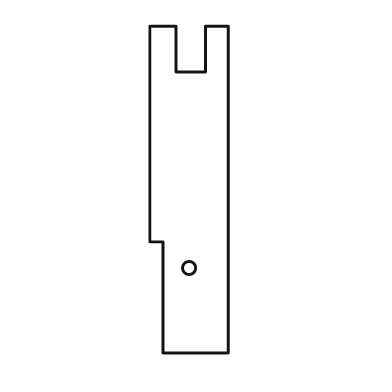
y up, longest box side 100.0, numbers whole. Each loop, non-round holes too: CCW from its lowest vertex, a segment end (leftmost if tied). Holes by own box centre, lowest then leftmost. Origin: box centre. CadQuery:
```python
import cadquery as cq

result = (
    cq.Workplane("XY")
    .moveTo(-8.0, -50.0)
    .lineTo(12.0, -50.0)
    .lineTo(12.0, 50.0)
    .lineTo(5.0, 50.0)
    .lineTo(5.0, 36.0)
    .lineTo(-4.0, 36.0)
    .lineTo(-4.0, 50.0)
    .lineTo(-12.0, 50.0)
    .lineTo(-12.0, -16.0)
    .lineTo(-8.0, -16.0)
    .close()
    .moveTo(0.0, -24.0)
    .circle(2.0)
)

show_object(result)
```